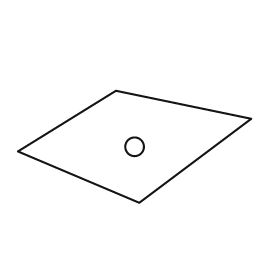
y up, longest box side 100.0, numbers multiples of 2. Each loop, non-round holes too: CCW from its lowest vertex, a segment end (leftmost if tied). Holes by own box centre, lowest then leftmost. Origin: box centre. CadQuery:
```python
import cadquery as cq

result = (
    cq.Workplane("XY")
    .moveTo(2.0, -24.0)
    .lineTo(50.0, 12.0)
    .lineTo(-8.0, 24.0)
    .lineTo(-50.0, -2.0)
    .close()
    .moveTo(0.0, 0.0)
    .circle(4.0)
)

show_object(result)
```